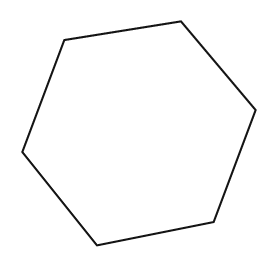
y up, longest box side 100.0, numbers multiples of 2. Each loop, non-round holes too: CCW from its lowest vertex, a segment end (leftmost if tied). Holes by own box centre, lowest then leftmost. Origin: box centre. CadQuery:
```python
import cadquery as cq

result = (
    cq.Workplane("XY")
    .moveTo(-18.0, -48.0)
    .lineTo(32.0, -38.0)
    .lineTo(50.0, 10.0)
    .lineTo(18.0, 48.0)
    .lineTo(-32.0, 40.0)
    .lineTo(-50.0, -8.0)
    .close()
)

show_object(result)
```